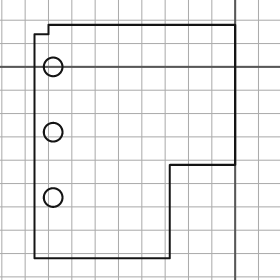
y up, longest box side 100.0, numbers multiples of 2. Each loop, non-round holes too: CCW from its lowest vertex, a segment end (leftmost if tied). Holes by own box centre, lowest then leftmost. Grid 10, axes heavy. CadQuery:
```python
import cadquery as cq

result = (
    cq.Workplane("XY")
    .moveTo(-86.0, -82.0)
    .lineTo(-28.0, -82.0)
    .lineTo(-28.0, -42.0)
    .lineTo(0.0, -42.0)
    .lineTo(0.0, 18.0)
    .lineTo(-80.0, 18.0)
    .lineTo(-80.0, 14.0)
    .lineTo(-86.0, 14.0)
    .close()
    .moveTo(-78.0, -56.0)
    .circle(4.0)
    .moveTo(-78.0, -28.0)
    .circle(4.0)
    .moveTo(-78.0, 0.0)
    .circle(4.0)
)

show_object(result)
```